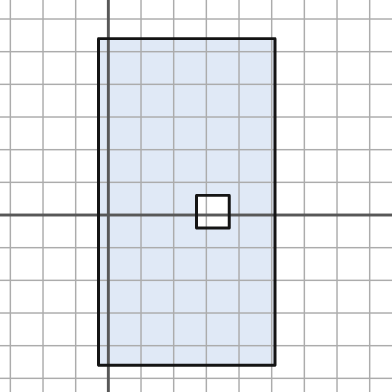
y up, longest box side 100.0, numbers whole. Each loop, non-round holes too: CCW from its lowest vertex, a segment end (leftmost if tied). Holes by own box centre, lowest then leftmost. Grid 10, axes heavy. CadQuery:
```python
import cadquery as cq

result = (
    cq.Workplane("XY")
    .moveTo(-3.0, -46.0)
    .lineTo(51.0, -46.0)
    .lineTo(51.0, 54.0)
    .lineTo(-3.0, 54.0)
    .close()
    .moveTo(27.0, -4.0)
    .lineTo(37.0, -4.0)
    .lineTo(37.0, 6.0)
    .lineTo(27.0, 6.0)
    .close()
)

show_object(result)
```